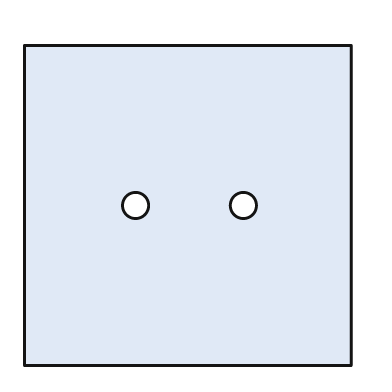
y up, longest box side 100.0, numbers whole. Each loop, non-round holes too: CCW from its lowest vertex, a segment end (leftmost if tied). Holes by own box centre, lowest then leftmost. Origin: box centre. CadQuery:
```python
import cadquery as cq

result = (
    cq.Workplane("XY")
    .moveTo(-50.0, -49.0)
    .lineTo(50.0, -49.0)
    .lineTo(50.0, 49.0)
    .lineTo(-50.0, 49.0)
    .close()
    .moveTo(-16.0, 0.0)
    .circle(4.0)
    .moveTo(17.0, 0.0)
    .circle(4.0)
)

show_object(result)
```